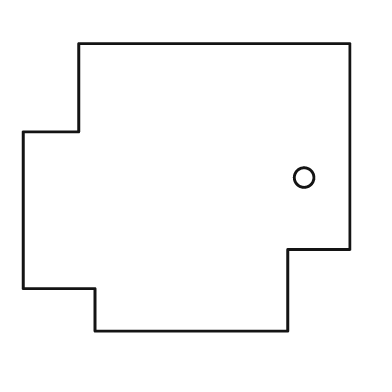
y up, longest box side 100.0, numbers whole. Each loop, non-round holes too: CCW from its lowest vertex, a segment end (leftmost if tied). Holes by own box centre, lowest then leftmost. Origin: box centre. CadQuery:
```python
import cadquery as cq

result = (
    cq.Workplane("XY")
    .moveTo(-28.0, -44.0)
    .lineTo(31.0, -44.0)
    .lineTo(31.0, -19.0)
    .lineTo(50.0, -19.0)
    .lineTo(50.0, 44.0)
    .lineTo(-33.0, 44.0)
    .lineTo(-33.0, 17.0)
    .lineTo(-50.0, 17.0)
    .lineTo(-50.0, -31.0)
    .lineTo(-28.0, -31.0)
    .close()
    .moveTo(36.0, 3.0)
    .circle(3.0)
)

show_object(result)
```